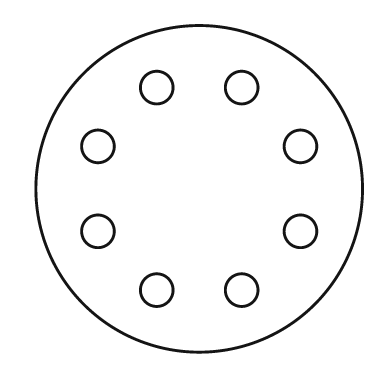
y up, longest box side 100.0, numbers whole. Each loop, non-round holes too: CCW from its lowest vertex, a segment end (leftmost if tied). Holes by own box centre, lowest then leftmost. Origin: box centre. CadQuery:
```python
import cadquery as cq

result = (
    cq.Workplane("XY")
    .moveTo(0.0, 0.0)
    .circle(50.0)
    .moveTo(-13.0, -31.0)
    .circle(5.0)
    .moveTo(13.0, -31.0)
    .circle(5.0)
    .moveTo(-31.0, -13.0)
    .circle(5.0)
    .moveTo(31.0, -13.0)
    .circle(5.0)
    .moveTo(-31.0, 13.0)
    .circle(5.0)
    .moveTo(31.0, 13.0)
    .circle(5.0)
    .moveTo(-13.0, 31.0)
    .circle(5.0)
    .moveTo(13.0, 31.0)
    .circle(5.0)
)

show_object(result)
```